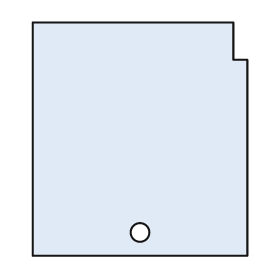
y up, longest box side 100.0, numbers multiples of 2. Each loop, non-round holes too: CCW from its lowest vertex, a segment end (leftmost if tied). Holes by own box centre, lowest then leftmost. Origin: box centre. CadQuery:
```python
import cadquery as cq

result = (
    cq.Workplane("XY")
    .moveTo(-46.0, -50.0)
    .lineTo(46.0, -50.0)
    .lineTo(46.0, 34.0)
    .lineTo(40.0, 34.0)
    .lineTo(40.0, 50.0)
    .lineTo(-46.0, 50.0)
    .close()
    .moveTo(0.0, -40.0)
    .circle(4.0)
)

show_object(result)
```